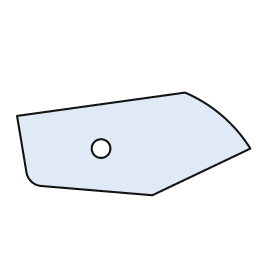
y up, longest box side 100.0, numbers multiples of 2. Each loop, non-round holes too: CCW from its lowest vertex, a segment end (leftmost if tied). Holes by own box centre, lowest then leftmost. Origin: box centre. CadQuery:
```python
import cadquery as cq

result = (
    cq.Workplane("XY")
    .moveTo(8.0, -22.0)
    .lineTo(50.0, -2.0)
    .threePointArc((38.0, 12.0), (22.0, 22.0))
    .lineTo(-50.0, 12.0)
    .lineTo(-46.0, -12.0)
    .threePointArc((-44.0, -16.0), (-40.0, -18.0))
    .close()
    .moveTo(-14.0, -2.0)
    .circle(4.0)
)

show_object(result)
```